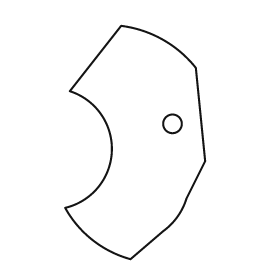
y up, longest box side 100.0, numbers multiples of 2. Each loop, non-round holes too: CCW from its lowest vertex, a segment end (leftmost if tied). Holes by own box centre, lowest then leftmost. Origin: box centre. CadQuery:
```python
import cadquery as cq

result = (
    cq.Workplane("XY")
    .moveTo(-2.0, -50.0)
    .lineTo(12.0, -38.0)
    .threePointArc((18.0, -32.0), (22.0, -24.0))
    .lineTo(30.0, -8.0)
    .lineTo(26.0, 32.0)
    .threePointArc((12.0, 44.0), (-6.0, 50.0))
    .lineTo(-28.0, 22.0)
    .threePointArc((-10.0, -4.0), (-30.0, -28.0))
    .threePointArc((-18.0, -42.0), (-2.0, -50.0))
    .close()
    .moveTo(16.0, 8.0)
    .circle(4.0)
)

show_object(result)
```